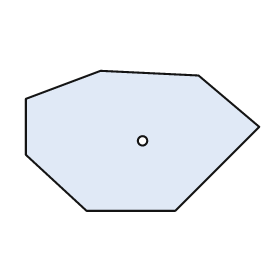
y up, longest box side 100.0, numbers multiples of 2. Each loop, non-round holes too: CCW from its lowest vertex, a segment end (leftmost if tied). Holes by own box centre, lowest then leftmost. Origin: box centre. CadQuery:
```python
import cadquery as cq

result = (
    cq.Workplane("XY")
    .moveTo(-24.0, -30.0)
    .lineTo(14.0, -30.0)
    .lineTo(50.0, 6.0)
    .lineTo(24.0, 28.0)
    .lineTo(-18.0, 30.0)
    .lineTo(-50.0, 18.0)
    .lineTo(-50.0, -6.0)
    .close()
    .moveTo(0.0, 0.0)
    .circle(2.0)
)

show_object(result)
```